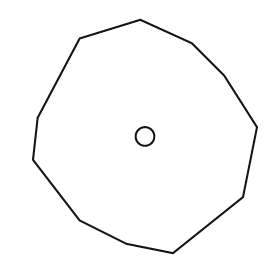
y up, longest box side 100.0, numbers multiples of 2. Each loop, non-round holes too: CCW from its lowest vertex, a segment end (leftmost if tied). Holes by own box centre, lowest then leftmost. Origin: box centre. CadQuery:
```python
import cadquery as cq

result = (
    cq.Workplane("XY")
    .moveTo(12.0, -50.0)
    .lineTo(42.0, -26.0)
    .lineTo(48.0, 4.0)
    .lineTo(34.0, 26.0)
    .lineTo(20.0, 40.0)
    .lineTo(-2.0, 50.0)
    .lineTo(-28.0, 42.0)
    .lineTo(-46.0, 8.0)
    .lineTo(-48.0, -10.0)
    .lineTo(-28.0, -36.0)
    .lineTo(-8.0, -46.0)
    .close()
    .moveTo(0.0, 0.0)
    .circle(4.0)
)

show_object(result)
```